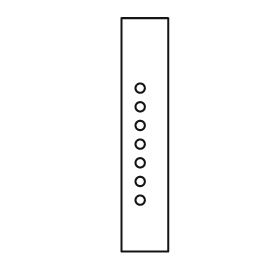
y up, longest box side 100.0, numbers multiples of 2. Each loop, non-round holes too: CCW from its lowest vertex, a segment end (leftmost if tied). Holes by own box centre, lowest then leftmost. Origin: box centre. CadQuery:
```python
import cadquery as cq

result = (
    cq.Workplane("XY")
    .moveTo(-10.0, -50.0)
    .lineTo(10.0, -50.0)
    .lineTo(10.0, 50.0)
    .lineTo(-10.0, 50.0)
    .close()
    .moveTo(-2.0, -28.0)
    .circle(2.0)
    .moveTo(-2.0, -20.0)
    .circle(2.0)
    .moveTo(-2.0, -12.0)
    .circle(2.0)
    .moveTo(-2.0, -4.0)
    .circle(2.0)
    .moveTo(-2.0, 4.0)
    .circle(2.0)
    .moveTo(-2.0, 12.0)
    .circle(2.0)
    .moveTo(-2.0, 20.0)
    .circle(2.0)
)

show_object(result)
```